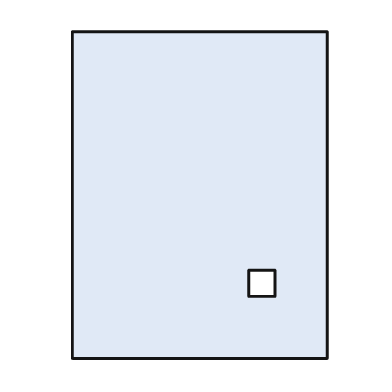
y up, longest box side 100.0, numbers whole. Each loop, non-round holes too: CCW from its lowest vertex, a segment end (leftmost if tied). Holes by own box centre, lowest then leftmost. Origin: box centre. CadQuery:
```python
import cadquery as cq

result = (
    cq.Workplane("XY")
    .moveTo(-39.0, -50.0)
    .lineTo(39.0, -50.0)
    .lineTo(39.0, 50.0)
    .lineTo(-39.0, 50.0)
    .close()
    .moveTo(15.0, -31.0)
    .lineTo(23.0, -31.0)
    .lineTo(23.0, -23.0)
    .lineTo(15.0, -23.0)
    .close()
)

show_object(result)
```